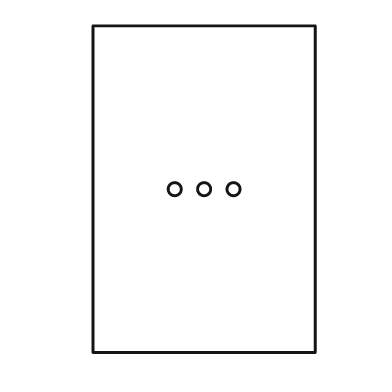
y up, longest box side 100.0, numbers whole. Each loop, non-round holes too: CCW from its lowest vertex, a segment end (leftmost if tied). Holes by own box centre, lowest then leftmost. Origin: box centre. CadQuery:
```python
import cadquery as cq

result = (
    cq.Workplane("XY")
    .moveTo(-34.0, -50.0)
    .lineTo(34.0, -50.0)
    .lineTo(34.0, 50.0)
    .lineTo(-34.0, 50.0)
    .close()
    .moveTo(-9.0, 0.0)
    .circle(2.0)
    .moveTo(0.0, 0.0)
    .circle(2.0)
    .moveTo(9.0, 0.0)
    .circle(2.0)
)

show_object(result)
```